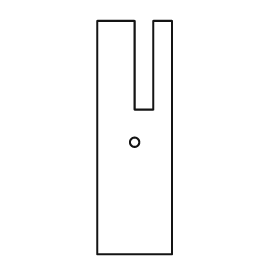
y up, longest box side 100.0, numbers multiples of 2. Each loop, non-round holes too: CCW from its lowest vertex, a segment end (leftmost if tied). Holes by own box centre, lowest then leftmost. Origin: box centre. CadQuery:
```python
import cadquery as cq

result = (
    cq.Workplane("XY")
    .moveTo(-16.0, -50.0)
    .lineTo(16.0, -50.0)
    .lineTo(16.0, 50.0)
    .lineTo(8.0, 50.0)
    .lineTo(8.0, 12.0)
    .lineTo(0.0, 12.0)
    .lineTo(0.0, 50.0)
    .lineTo(-16.0, 50.0)
    .close()
    .moveTo(0.0, -2.0)
    .circle(2.0)
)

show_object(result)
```